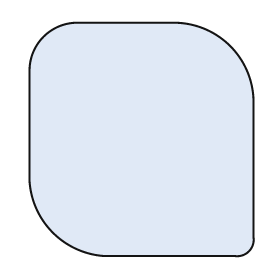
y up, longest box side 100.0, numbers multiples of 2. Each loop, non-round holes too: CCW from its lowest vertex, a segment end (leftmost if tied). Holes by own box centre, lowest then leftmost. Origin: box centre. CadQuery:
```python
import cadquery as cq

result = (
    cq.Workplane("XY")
    .moveTo(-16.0, -50.0)
    .lineTo(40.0, -50.0)
    .threePointArc((46.0, -48.0), (48.0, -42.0))
    .lineTo(48.0, 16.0)
    .threePointArc((38.0, 40.0), (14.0, 50.0))
    .lineTo(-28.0, 50.0)
    .threePointArc((-42.0, 44.0), (-48.0, 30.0))
    .lineTo(-48.0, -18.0)
    .threePointArc((-38.0, -40.0), (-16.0, -50.0))
    .close()
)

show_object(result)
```